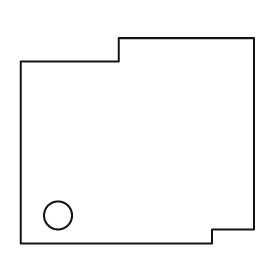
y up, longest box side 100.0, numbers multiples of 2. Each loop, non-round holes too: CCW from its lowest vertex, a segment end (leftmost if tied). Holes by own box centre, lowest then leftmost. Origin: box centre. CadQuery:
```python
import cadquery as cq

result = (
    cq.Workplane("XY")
    .moveTo(-50.0, -44.0)
    .lineTo(32.0, -44.0)
    .lineTo(32.0, -38.0)
    .lineTo(50.0, -38.0)
    .lineTo(50.0, 44.0)
    .lineTo(-8.0, 44.0)
    .lineTo(-8.0, 34.0)
    .lineTo(-50.0, 34.0)
    .close()
    .moveTo(-34.0, -32.0)
    .circle(6.0)
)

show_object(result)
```